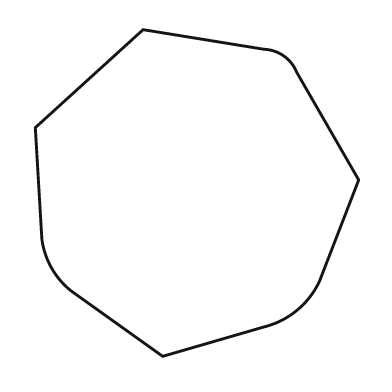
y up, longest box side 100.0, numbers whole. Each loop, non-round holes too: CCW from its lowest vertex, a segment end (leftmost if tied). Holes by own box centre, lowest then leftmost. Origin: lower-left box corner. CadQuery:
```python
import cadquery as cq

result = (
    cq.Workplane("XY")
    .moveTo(39.0, 0.0)
    .lineTo(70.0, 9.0)
    .threePointArc((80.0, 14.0), (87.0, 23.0))
    .lineTo(99.0, 54.0)
    .lineTo(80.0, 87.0)
    .threePointArc((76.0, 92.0), (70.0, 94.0))
    .lineTo(33.0, 100.0)
    .lineTo(0.0, 70.0)
    .lineTo(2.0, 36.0)
    .threePointArc((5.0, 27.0), (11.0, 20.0))
    .close()
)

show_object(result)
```